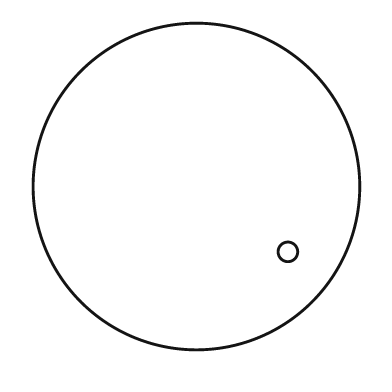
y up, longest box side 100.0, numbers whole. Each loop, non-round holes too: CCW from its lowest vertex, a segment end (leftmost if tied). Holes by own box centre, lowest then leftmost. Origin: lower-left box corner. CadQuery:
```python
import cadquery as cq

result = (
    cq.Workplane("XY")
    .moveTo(50.0, 50.0)
    .circle(50.0)
    .moveTo(78.0, 30.0)
    .circle(3.0)
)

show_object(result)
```